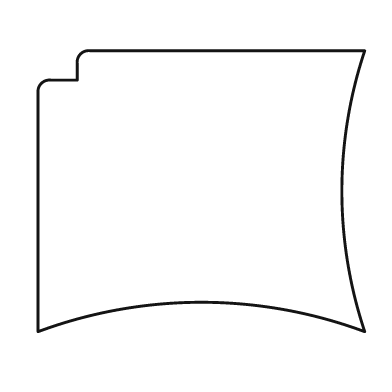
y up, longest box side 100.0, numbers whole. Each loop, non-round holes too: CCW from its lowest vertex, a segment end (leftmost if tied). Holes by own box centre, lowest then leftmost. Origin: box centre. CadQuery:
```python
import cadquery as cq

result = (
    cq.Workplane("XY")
    .moveTo(-50.0, -43.0)
    .threePointArc((0.0, -34.0), (50.0, -43.0))
    .threePointArc((43.0, 0.0), (50.0, 43.0))
    .lineTo(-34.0, 43.0)
    .threePointArc((-37.0, 42.0), (-38.0, 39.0))
    .lineTo(-38.0, 34.0)
    .lineTo(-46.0, 34.0)
    .threePointArc((-49.0, 33.0), (-50.0, 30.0))
    .close()
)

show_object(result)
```